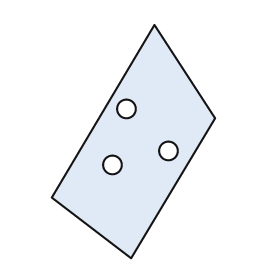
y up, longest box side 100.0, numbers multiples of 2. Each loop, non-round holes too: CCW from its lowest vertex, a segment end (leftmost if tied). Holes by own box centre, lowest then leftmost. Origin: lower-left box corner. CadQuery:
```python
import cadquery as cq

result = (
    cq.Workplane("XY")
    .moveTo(34.0, 0.0)
    .lineTo(70.0, 60.0)
    .lineTo(44.0, 100.0)
    .lineTo(0.0, 26.0)
    .close()
    .moveTo(26.0, 40.0)
    .circle(4.0)
    .moveTo(50.0, 46.0)
    .circle(4.0)
    .moveTo(32.0, 64.0)
    .circle(4.0)
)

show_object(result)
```